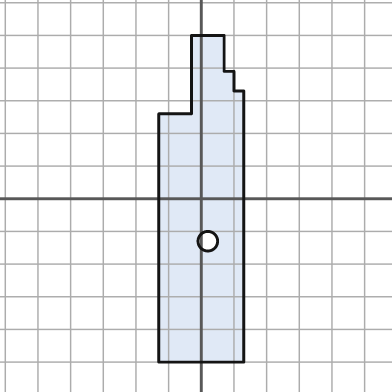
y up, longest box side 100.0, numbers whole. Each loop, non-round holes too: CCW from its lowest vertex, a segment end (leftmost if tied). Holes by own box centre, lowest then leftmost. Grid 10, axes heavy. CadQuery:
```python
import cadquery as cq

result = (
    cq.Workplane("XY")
    .moveTo(-13.0, -50.0)
    .lineTo(13.0, -50.0)
    .lineTo(13.0, 33.0)
    .lineTo(10.0, 33.0)
    .lineTo(10.0, 39.0)
    .lineTo(7.0, 39.0)
    .lineTo(7.0, 50.0)
    .lineTo(-3.0, 50.0)
    .lineTo(-3.0, 26.0)
    .lineTo(-13.0, 26.0)
    .close()
    .moveTo(2.0, -13.0)
    .circle(3.0)
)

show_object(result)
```